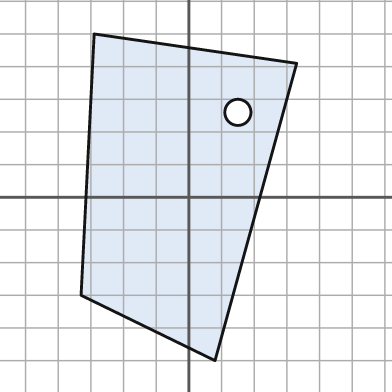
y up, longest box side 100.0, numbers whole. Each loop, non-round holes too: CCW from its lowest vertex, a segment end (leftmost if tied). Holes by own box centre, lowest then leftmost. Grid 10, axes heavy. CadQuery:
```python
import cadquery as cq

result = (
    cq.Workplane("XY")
    .moveTo(8.0, -50.0)
    .lineTo(33.0, 41.0)
    .lineTo(-29.0, 50.0)
    .lineTo(-33.0, -30.0)
    .close()
    .moveTo(15.0, 26.0)
    .circle(4.0)
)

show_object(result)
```